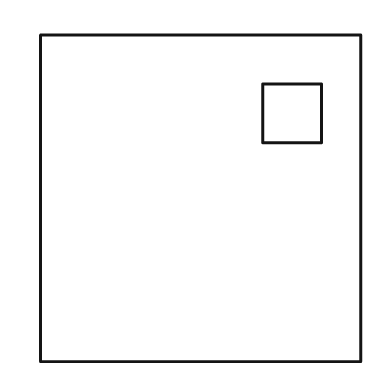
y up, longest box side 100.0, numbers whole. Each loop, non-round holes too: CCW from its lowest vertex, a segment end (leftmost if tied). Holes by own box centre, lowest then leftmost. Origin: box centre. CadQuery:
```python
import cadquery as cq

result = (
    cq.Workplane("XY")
    .moveTo(-49.0, -50.0)
    .lineTo(49.0, -50.0)
    .lineTo(49.0, 50.0)
    .lineTo(-49.0, 50.0)
    .close()
    .moveTo(19.0, 17.0)
    .lineTo(37.0, 17.0)
    .lineTo(37.0, 35.0)
    .lineTo(19.0, 35.0)
    .close()
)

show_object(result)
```